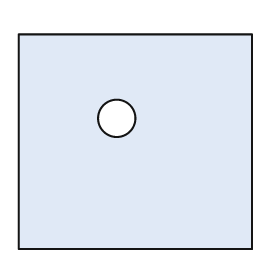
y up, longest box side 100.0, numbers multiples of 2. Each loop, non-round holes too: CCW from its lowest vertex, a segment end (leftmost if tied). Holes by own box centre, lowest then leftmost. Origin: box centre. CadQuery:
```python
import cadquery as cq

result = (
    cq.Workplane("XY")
    .moveTo(-50.0, -46.0)
    .lineTo(50.0, -46.0)
    .lineTo(50.0, 46.0)
    .lineTo(-50.0, 46.0)
    .close()
    .moveTo(-8.0, 10.0)
    .circle(8.0)
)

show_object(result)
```